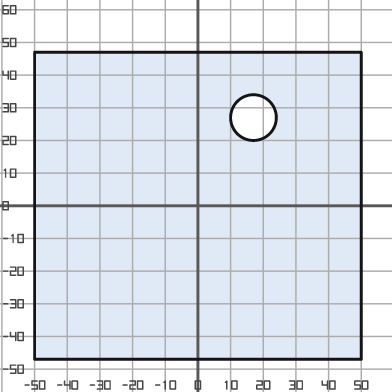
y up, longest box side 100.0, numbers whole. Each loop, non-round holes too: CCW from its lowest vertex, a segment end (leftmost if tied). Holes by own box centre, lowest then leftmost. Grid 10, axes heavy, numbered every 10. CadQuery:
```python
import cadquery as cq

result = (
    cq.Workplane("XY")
    .moveTo(-50.0, -47.0)
    .lineTo(50.0, -47.0)
    .lineTo(50.0, 47.0)
    .lineTo(-50.0, 47.0)
    .close()
    .moveTo(17.0, 27.0)
    .circle(7.0)
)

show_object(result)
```